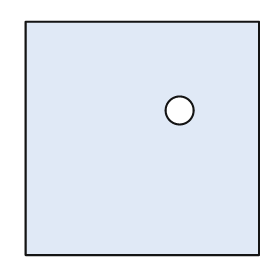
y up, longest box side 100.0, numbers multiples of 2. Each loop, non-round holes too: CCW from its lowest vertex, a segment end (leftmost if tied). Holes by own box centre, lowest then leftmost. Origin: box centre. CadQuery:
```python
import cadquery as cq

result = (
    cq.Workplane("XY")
    .moveTo(-50.0, -50.0)
    .lineTo(50.0, -50.0)
    .lineTo(50.0, 50.0)
    .lineTo(-50.0, 50.0)
    .close()
    .moveTo(16.0, 12.0)
    .circle(6.0)
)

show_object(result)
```